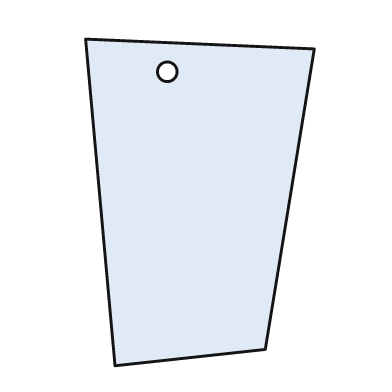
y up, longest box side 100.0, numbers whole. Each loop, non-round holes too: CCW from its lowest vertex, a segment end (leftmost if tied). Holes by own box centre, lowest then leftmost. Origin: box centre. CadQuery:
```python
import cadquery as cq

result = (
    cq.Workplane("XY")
    .moveTo(-26.0, -50.0)
    .lineTo(20.0, -45.0)
    .lineTo(35.0, 47.0)
    .lineTo(-35.0, 50.0)
    .close()
    .moveTo(-10.0, 40.0)
    .circle(3.0)
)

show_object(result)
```